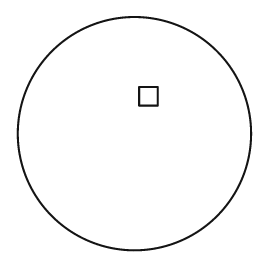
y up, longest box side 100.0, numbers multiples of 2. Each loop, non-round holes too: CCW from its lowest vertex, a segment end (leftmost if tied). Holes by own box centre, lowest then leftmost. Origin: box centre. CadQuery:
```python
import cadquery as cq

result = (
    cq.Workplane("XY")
    .moveTo(0.0, 0.0)
    .circle(50.0)
    .moveTo(2.0, 12.0)
    .lineTo(10.0, 12.0)
    .lineTo(10.0, 20.0)
    .lineTo(2.0, 20.0)
    .close()
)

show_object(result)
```